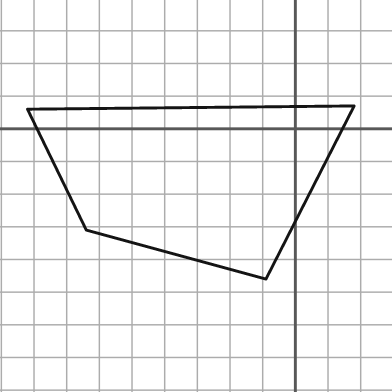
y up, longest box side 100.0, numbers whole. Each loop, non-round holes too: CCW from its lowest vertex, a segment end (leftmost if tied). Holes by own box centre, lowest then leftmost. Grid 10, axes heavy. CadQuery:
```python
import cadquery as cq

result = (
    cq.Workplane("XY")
    .moveTo(-9.0, -46.0)
    .lineTo(18.0, 7.0)
    .lineTo(-82.0, 6.0)
    .lineTo(-64.0, -31.0)
    .close()
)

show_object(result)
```